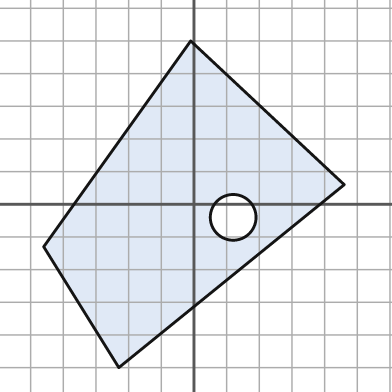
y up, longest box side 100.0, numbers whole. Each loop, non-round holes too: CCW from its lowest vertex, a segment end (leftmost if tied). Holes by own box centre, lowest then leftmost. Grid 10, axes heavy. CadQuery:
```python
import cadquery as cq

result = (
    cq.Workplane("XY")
    .moveTo(-23.0, -50.0)
    .lineTo(46.0, 6.0)
    .lineTo(-1.0, 50.0)
    .lineTo(-46.0, -13.0)
    .close()
    .moveTo(12.0, -4.0)
    .circle(7.0)
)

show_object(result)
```